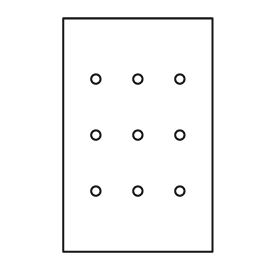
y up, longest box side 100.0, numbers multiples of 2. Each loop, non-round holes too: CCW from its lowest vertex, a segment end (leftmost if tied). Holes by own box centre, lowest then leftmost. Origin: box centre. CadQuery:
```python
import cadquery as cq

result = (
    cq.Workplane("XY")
    .moveTo(-32.0, -50.0)
    .lineTo(32.0, -50.0)
    .lineTo(32.0, 50.0)
    .lineTo(-32.0, 50.0)
    .close()
    .moveTo(-18.0, -24.0)
    .circle(2.0)
    .moveTo(0.0, -24.0)
    .circle(2.0)
    .moveTo(18.0, -24.0)
    .circle(2.0)
    .moveTo(-18.0, 0.0)
    .circle(2.0)
    .moveTo(0.0, 0.0)
    .circle(2.0)
    .moveTo(18.0, 0.0)
    .circle(2.0)
    .moveTo(-18.0, 24.0)
    .circle(2.0)
    .moveTo(0.0, 24.0)
    .circle(2.0)
    .moveTo(18.0, 24.0)
    .circle(2.0)
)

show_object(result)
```